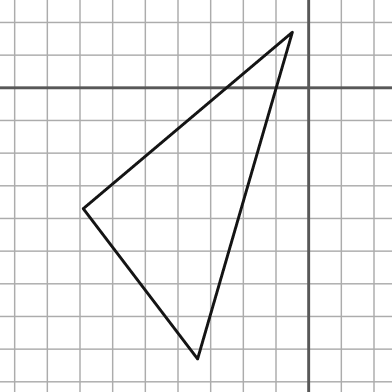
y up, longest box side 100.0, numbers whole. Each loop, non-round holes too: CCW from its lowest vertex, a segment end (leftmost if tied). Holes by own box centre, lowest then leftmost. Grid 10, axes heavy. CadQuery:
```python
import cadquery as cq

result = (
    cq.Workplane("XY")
    .moveTo(-34.0, -83.0)
    .lineTo(-5.0, 17.0)
    .lineTo(-69.0, -37.0)
    .close()
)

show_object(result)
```